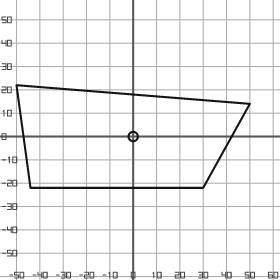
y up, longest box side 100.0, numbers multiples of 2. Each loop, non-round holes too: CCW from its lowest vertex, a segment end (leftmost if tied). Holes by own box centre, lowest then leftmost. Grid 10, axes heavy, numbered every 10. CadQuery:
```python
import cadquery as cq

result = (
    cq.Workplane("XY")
    .moveTo(-44.0, -22.0)
    .lineTo(30.0, -22.0)
    .lineTo(50.0, 14.0)
    .lineTo(-50.0, 22.0)
    .close()
    .moveTo(0.0, 0.0)
    .circle(2.0)
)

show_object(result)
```